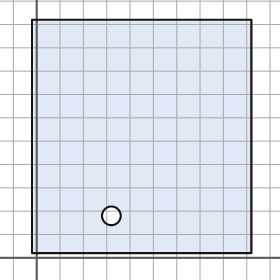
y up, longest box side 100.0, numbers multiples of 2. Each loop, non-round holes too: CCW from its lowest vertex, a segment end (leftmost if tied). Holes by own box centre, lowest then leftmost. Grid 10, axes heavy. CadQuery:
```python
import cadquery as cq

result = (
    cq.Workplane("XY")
    .moveTo(-2.0, 2.0)
    .lineTo(92.0, 2.0)
    .lineTo(92.0, 102.0)
    .lineTo(-2.0, 102.0)
    .close()
    .moveTo(32.0, 18.0)
    .circle(4.0)
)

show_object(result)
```